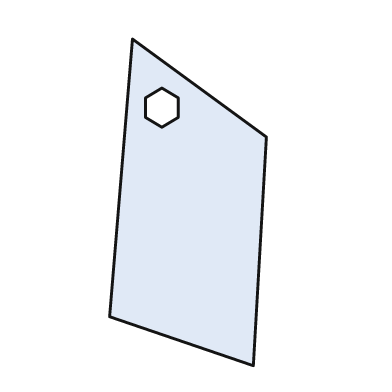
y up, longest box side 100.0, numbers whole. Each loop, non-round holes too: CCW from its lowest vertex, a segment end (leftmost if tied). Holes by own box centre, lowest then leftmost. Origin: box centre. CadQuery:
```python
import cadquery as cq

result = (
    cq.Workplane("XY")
    .moveTo(20.0, -50.0)
    .lineTo(24.0, 20.0)
    .lineTo(-17.0, 50.0)
    .lineTo(-24.0, -35.0)
    .close()
    .moveTo(-8.0, 23.0)
    .lineTo(-3.0, 26.0)
    .lineTo(-3.0, 32.0)
    .lineTo(-8.0, 35.0)
    .lineTo(-13.0, 32.0)
    .lineTo(-13.0, 26.0)
    .close()
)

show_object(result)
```